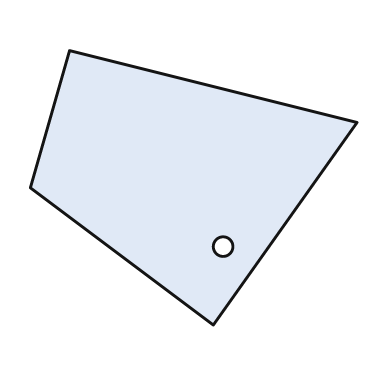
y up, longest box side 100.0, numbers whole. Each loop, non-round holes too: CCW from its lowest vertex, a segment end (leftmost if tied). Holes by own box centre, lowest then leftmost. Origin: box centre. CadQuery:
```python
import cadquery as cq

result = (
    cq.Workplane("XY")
    .moveTo(6.0, -42.0)
    .lineTo(50.0, 20.0)
    .lineTo(-38.0, 42.0)
    .lineTo(-50.0, 0.0)
    .close()
    .moveTo(9.0, -18.0)
    .circle(3.0)
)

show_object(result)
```